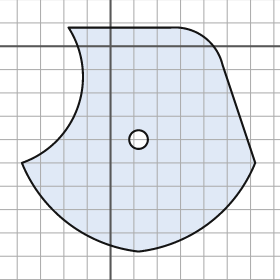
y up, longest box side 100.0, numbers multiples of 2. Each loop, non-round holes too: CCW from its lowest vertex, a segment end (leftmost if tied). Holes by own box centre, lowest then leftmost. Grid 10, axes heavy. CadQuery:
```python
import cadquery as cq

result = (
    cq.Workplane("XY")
    .moveTo(12.0, -88.0)
    .threePointArc((42.0, -76.0), (62.0, -50.0))
    .lineTo(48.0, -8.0)
    .threePointArc((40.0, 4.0), (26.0, 8.0))
    .lineTo(-18.0, 8.0)
    .threePointArc((-14.0, -26.0), (-38.0, -50.0))
    .threePointArc((-18.0, -76.0), (12.0, -88.0))
    .close()
    .moveTo(12.0, -40.0)
    .circle(4.0)
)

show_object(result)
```